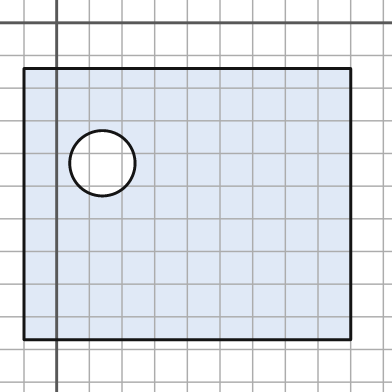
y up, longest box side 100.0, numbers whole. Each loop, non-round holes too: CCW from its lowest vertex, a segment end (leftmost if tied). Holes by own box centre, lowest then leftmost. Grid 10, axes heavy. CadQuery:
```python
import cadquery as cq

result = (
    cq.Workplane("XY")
    .moveTo(-10.0, -97.0)
    .lineTo(90.0, -97.0)
    .lineTo(90.0, -14.0)
    .lineTo(-10.0, -14.0)
    .close()
    .moveTo(14.0, -43.0)
    .circle(10.0)
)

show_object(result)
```